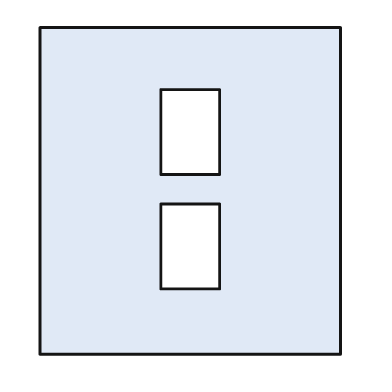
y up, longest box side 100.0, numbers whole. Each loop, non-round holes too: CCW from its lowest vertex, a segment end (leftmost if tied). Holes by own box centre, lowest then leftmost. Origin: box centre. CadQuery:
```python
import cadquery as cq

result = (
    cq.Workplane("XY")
    .moveTo(-46.0, -50.0)
    .lineTo(46.0, -50.0)
    .lineTo(46.0, 50.0)
    .lineTo(-46.0, 50.0)
    .close()
    .moveTo(-9.0, -30.0)
    .lineTo(9.0, -30.0)
    .lineTo(9.0, -4.0)
    .lineTo(-9.0, -4.0)
    .close()
    .moveTo(-9.0, 5.0)
    .lineTo(9.0, 5.0)
    .lineTo(9.0, 31.0)
    .lineTo(-9.0, 31.0)
    .close()
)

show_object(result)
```